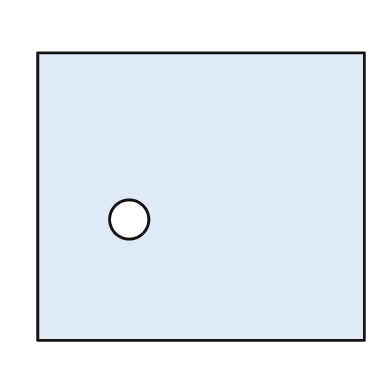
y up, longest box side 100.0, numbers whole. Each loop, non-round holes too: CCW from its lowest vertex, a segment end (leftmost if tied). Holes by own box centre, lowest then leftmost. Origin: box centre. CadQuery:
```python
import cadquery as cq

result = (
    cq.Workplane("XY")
    .moveTo(-50.0, -44.0)
    .lineTo(50.0, -44.0)
    .lineTo(50.0, 44.0)
    .lineTo(-50.0, 44.0)
    .close()
    .moveTo(-22.0, -7.0)
    .circle(6.0)
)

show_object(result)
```